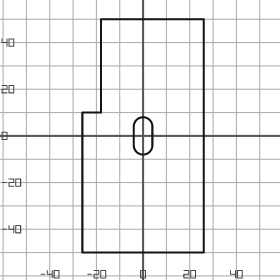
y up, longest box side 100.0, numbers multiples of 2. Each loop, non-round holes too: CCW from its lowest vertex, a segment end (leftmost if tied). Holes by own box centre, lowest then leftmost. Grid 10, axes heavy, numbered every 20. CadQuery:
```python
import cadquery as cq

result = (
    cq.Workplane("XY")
    .moveTo(-26.0, -50.0)
    .lineTo(26.0, -50.0)
    .lineTo(26.0, 50.0)
    .lineTo(-18.0, 50.0)
    .lineTo(-18.0, 10.0)
    .lineTo(-26.0, 10.0)
    .close()
    .moveTo(-4.0, -4.0)
    .threePointArc((0.0, -8.0), (4.0, -4.0))
    .lineTo(4.0, 4.0)
    .threePointArc((0.0, 8.0), (-4.0, 4.0))
    .close()
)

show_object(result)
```